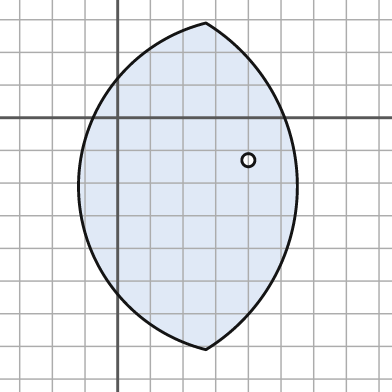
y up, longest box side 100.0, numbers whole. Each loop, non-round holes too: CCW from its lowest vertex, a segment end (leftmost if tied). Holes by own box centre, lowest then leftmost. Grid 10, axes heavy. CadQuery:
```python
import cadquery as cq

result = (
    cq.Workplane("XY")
    .moveTo(27.0, -71.0)
    .threePointArc((55.0, -21.0), (27.0, 29.0))
    .threePointArc((-12.0, -21.0), (27.0, -71.0))
    .close()
    .moveTo(40.0, -13.0)
    .circle(2.0)
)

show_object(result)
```